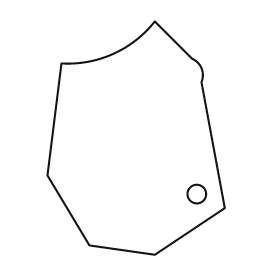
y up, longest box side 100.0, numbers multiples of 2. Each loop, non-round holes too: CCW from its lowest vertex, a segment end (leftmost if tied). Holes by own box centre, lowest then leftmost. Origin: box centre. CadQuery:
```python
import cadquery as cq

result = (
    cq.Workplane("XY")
    .moveTo(8.0, -50.0)
    .lineTo(38.0, -30.0)
    .lineTo(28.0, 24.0)
    .threePointArc((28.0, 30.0), (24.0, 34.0))
    .lineTo(8.0, 50.0)
    .threePointArc((-10.0, 36.0), (-32.0, 32.0))
    .lineTo(-38.0, -16.0)
    .lineTo(-20.0, -46.0)
    .close()
    .moveTo(26.0, -24.0)
    .circle(4.0)
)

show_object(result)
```